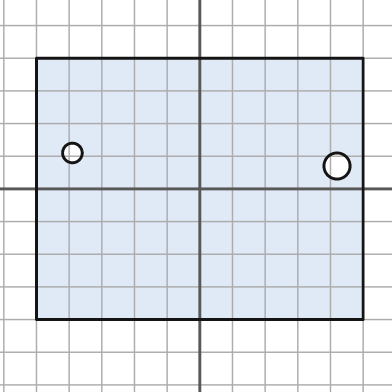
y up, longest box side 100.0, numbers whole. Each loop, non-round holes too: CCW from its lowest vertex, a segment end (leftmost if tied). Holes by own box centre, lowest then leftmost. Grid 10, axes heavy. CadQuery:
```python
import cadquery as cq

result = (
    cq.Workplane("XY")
    .moveTo(-50.0, -40.0)
    .lineTo(50.0, -40.0)
    .lineTo(50.0, 40.0)
    .lineTo(-50.0, 40.0)
    .close()
    .moveTo(42.0, 7.0)
    .circle(4.0)
    .moveTo(-39.0, 11.0)
    .circle(3.0)
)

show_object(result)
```